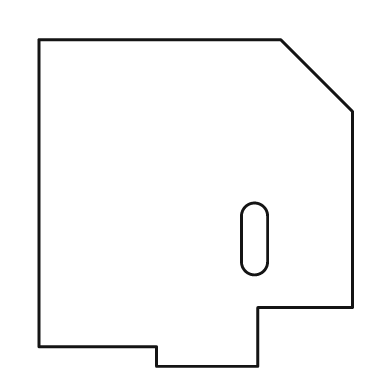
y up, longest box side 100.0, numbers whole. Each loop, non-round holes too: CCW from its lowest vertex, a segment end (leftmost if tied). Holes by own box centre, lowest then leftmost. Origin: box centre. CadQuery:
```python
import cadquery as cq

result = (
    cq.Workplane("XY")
    .moveTo(-12.0, -50.0)
    .lineTo(19.0, -50.0)
    .lineTo(19.0, -32.0)
    .lineTo(48.0, -32.0)
    .lineTo(48.0, 28.0)
    .lineTo(26.0, 50.0)
    .lineTo(-48.0, 50.0)
    .lineTo(-48.0, -44.0)
    .lineTo(-12.0, -44.0)
    .close()
    .moveTo(14.0, -18.0)
    .threePointArc((18.0, -22.0), (22.0, -18.0))
    .lineTo(22.0, -4.0)
    .threePointArc((18.0, 0.0), (14.0, -4.0))
    .close()
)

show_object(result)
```